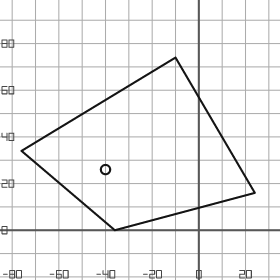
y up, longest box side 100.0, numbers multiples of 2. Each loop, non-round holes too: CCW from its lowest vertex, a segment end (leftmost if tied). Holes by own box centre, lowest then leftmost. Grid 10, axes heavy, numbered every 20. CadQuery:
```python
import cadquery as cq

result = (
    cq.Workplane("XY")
    .moveTo(-36.0, 0.0)
    .lineTo(24.0, 16.0)
    .lineTo(-10.0, 74.0)
    .lineTo(-76.0, 34.0)
    .close()
    .moveTo(-40.0, 26.0)
    .circle(2.0)
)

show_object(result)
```